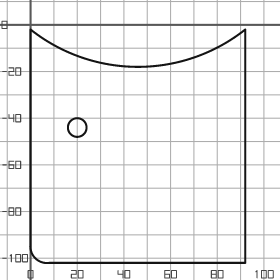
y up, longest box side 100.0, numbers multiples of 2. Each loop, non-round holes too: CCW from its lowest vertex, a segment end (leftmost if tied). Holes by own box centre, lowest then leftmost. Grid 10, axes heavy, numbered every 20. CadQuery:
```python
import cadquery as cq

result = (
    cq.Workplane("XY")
    .moveTo(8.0, -102.0)
    .lineTo(92.0, -102.0)
    .lineTo(92.0, -2.0)
    .threePointArc((46.0, -18.0), (0.0, -2.0))
    .lineTo(0.0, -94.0)
    .threePointArc((2.0, -100.0), (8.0, -102.0))
    .close()
    .moveTo(20.0, -44.0)
    .circle(4.0)
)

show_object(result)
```